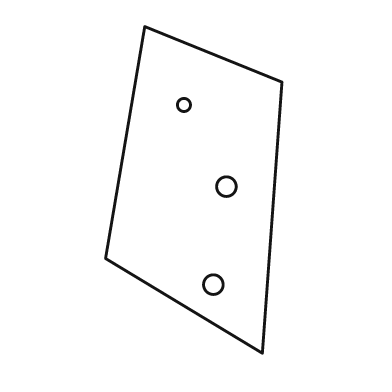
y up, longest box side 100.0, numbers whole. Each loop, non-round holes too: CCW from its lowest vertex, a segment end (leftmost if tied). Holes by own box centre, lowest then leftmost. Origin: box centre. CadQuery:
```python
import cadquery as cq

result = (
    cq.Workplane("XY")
    .moveTo(21.0, -50.0)
    .lineTo(27.0, 33.0)
    .lineTo(-15.0, 50.0)
    .lineTo(-27.0, -21.0)
    .close()
    .moveTo(6.0, -29.0)
    .circle(3.0)
    .moveTo(10.0, 1.0)
    .circle(3.0)
    .moveTo(-3.0, 26.0)
    .circle(2.0)
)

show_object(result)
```